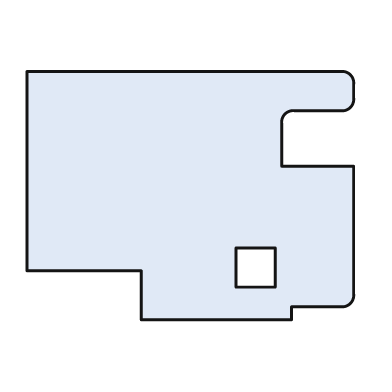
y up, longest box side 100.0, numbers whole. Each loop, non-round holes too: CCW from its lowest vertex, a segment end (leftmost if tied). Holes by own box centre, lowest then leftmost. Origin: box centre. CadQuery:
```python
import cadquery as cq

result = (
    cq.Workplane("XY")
    .moveTo(-15.0, -38.0)
    .lineTo(31.0, -38.0)
    .lineTo(31.0, -34.0)
    .lineTo(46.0, -34.0)
    .threePointArc((49.0, -33.0), (50.0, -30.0))
    .lineTo(50.0, 9.0)
    .lineTo(28.0, 9.0)
    .lineTo(28.0, 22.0)
    .threePointArc((29.0, 25.0), (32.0, 26.0))
    .lineTo(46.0, 26.0)
    .threePointArc((49.0, 27.0), (50.0, 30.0))
    .lineTo(50.0, 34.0)
    .threePointArc((49.0, 37.0), (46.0, 38.0))
    .lineTo(-50.0, 38.0)
    .lineTo(-50.0, -23.0)
    .lineTo(-15.0, -23.0)
    .close()
    .moveTo(14.0, -28.0)
    .lineTo(26.0, -28.0)
    .lineTo(26.0, -16.0)
    .lineTo(14.0, -16.0)
    .close()
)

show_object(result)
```